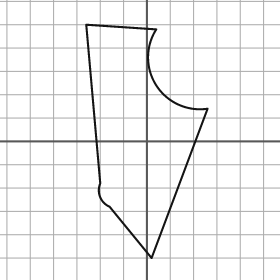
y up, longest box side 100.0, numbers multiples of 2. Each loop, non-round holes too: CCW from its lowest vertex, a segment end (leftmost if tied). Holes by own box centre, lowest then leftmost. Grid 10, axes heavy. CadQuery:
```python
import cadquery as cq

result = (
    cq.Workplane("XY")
    .moveTo(2.0, -50.0)
    .lineTo(26.0, 14.0)
    .threePointArc((4.0, 24.0), (4.0, 48.0))
    .lineTo(-26.0, 50.0)
    .lineTo(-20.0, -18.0)
    .threePointArc((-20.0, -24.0), (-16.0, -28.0))
    .close()
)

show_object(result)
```